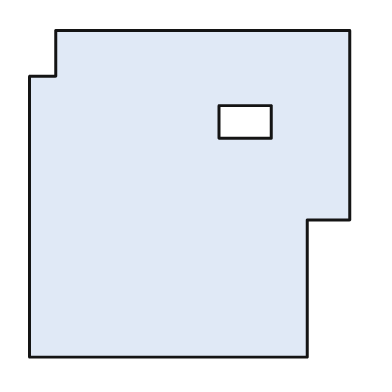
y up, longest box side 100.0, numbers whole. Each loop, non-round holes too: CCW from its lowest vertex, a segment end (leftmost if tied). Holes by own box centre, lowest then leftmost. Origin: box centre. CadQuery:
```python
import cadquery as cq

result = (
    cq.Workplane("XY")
    .moveTo(-49.0, -50.0)
    .lineTo(36.0, -50.0)
    .lineTo(36.0, -8.0)
    .lineTo(49.0, -8.0)
    .lineTo(49.0, 50.0)
    .lineTo(-41.0, 50.0)
    .lineTo(-41.0, 36.0)
    .lineTo(-49.0, 36.0)
    .close()
    .moveTo(9.0, 17.0)
    .lineTo(25.0, 17.0)
    .lineTo(25.0, 27.0)
    .lineTo(9.0, 27.0)
    .close()
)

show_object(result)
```